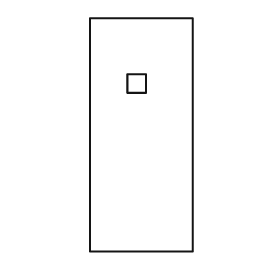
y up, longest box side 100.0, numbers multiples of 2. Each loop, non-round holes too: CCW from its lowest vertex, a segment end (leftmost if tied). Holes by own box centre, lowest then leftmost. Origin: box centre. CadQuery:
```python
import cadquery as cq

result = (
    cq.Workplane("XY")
    .moveTo(-22.0, -50.0)
    .lineTo(22.0, -50.0)
    .lineTo(22.0, 50.0)
    .lineTo(-22.0, 50.0)
    .close()
    .moveTo(-6.0, 18.0)
    .lineTo(2.0, 18.0)
    .lineTo(2.0, 26.0)
    .lineTo(-6.0, 26.0)
    .close()
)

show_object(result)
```